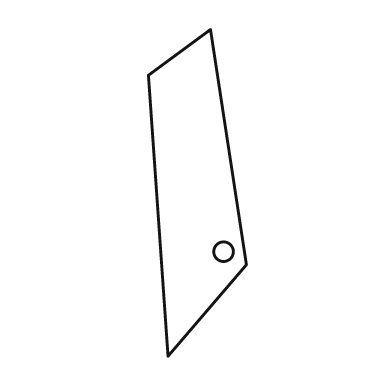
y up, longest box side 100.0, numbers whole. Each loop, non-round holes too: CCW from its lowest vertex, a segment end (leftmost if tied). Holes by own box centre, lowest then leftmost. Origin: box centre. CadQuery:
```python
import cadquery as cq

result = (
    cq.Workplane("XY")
    .moveTo(-9.0, -50.0)
    .lineTo(15.0, -22.0)
    .lineTo(4.0, 50.0)
    .lineTo(-15.0, 36.0)
    .close()
    .moveTo(8.0, -18.0)
    .circle(3.0)
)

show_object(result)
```